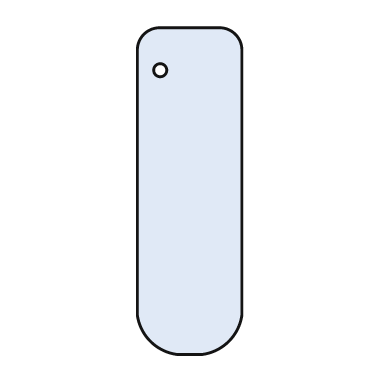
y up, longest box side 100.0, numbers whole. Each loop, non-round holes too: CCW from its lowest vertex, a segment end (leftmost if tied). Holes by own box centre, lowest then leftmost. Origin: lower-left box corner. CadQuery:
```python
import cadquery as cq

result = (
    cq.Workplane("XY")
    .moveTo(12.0, 0.0)
    .lineTo(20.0, 0.0)
    .threePointArc((28.0, 4.0), (32.0, 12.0))
    .lineTo(32.0, 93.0)
    .threePointArc((30.0, 98.0), (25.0, 100.0))
    .lineTo(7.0, 100.0)
    .threePointArc((2.0, 98.0), (0.0, 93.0))
    .lineTo(0.0, 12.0)
    .threePointArc((4.0, 4.0), (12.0, 0.0))
    .close()
    .moveTo(7.0, 87.0)
    .circle(2.0)
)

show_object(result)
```